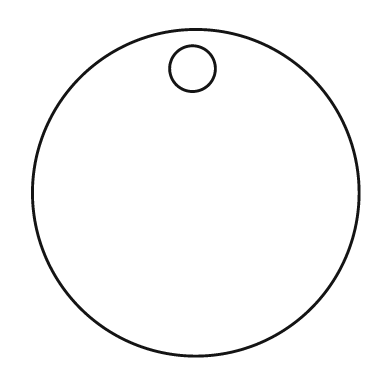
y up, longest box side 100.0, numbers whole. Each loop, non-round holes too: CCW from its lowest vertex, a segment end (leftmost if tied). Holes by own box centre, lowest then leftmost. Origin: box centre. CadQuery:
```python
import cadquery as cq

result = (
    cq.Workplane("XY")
    .moveTo(0.0, 0.0)
    .circle(50.0)
    .moveTo(-1.0, 38.0)
    .circle(7.0)
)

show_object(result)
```